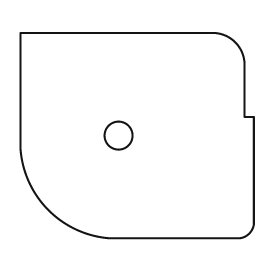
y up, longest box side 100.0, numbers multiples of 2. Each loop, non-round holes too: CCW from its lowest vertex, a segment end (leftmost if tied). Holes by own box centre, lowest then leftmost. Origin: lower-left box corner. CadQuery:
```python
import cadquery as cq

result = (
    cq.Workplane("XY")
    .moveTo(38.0, 0.0)
    .lineTo(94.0, 0.0)
    .threePointArc((98.0, 2.0), (100.0, 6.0))
    .lineTo(100.0, 52.0)
    .lineTo(96.0, 52.0)
    .lineTo(96.0, 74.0)
    .threePointArc((92.0, 84.0), (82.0, 88.0))
    .lineTo(0.0, 88.0)
    .lineTo(0.0, 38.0)
    .threePointArc((12.0, 12.0), (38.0, 0.0))
    .close()
    .moveTo(42.0, 44.0)
    .circle(6.0)
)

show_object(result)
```